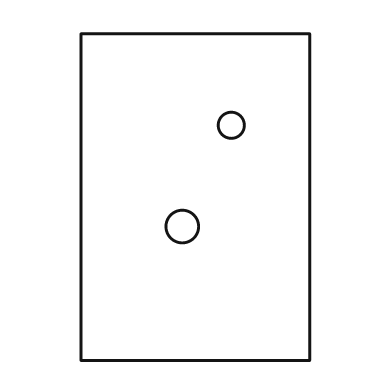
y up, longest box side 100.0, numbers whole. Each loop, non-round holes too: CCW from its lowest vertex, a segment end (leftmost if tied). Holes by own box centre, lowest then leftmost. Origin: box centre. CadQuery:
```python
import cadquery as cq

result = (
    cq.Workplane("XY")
    .moveTo(-35.0, -50.0)
    .lineTo(35.0, -50.0)
    .lineTo(35.0, 50.0)
    .lineTo(-35.0, 50.0)
    .close()
    .moveTo(-4.0, -9.0)
    .circle(5.0)
    .moveTo(11.0, 22.0)
    .circle(4.0)
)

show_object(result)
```